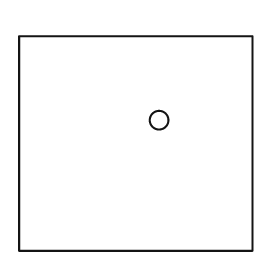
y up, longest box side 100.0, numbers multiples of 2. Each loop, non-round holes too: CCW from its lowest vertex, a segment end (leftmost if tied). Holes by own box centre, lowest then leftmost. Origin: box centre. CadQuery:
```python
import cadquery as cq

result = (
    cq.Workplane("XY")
    .moveTo(-50.0, -46.0)
    .lineTo(50.0, -46.0)
    .lineTo(50.0, 46.0)
    .lineTo(-50.0, 46.0)
    .close()
    .moveTo(10.0, 10.0)
    .circle(4.0)
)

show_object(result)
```